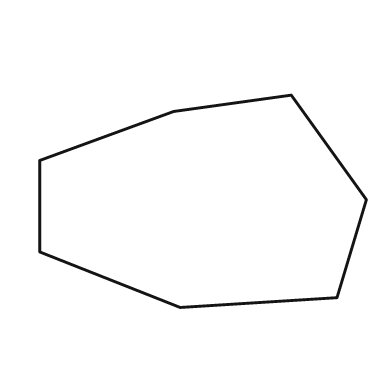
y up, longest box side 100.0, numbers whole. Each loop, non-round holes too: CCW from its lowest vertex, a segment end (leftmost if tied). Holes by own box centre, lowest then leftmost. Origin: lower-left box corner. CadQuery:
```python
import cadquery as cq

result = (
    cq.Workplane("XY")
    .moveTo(43.0, 0.0)
    .lineTo(91.0, 3.0)
    .lineTo(100.0, 33.0)
    .lineTo(77.0, 65.0)
    .lineTo(41.0, 60.0)
    .lineTo(0.0, 45.0)
    .lineTo(0.0, 17.0)
    .close()
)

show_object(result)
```